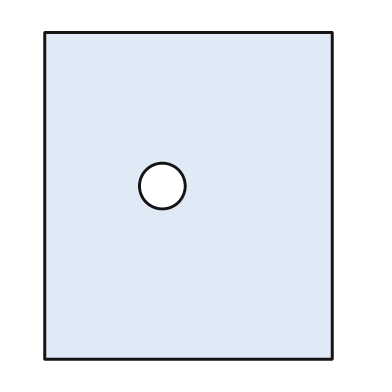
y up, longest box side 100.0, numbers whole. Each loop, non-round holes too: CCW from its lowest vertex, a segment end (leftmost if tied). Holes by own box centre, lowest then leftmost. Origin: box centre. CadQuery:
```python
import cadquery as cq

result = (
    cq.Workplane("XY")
    .moveTo(-44.0, -50.0)
    .lineTo(44.0, -50.0)
    .lineTo(44.0, 50.0)
    .lineTo(-44.0, 50.0)
    .close()
    .moveTo(-8.0, 3.0)
    .circle(7.0)
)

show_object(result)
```